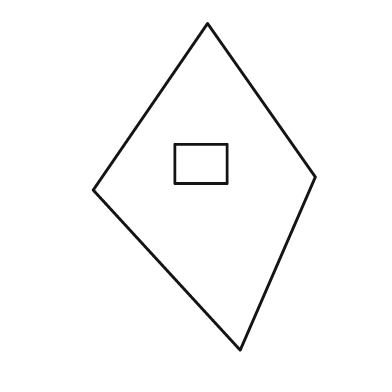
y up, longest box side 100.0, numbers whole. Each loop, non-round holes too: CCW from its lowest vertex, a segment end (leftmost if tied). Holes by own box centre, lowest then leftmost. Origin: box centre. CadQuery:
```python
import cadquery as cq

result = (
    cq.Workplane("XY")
    .moveTo(11.0, -50.0)
    .lineTo(34.0, 3.0)
    .lineTo(1.0, 50.0)
    .lineTo(-34.0, -1.0)
    .close()
    .moveTo(-9.0, 1.0)
    .lineTo(7.0, 1.0)
    .lineTo(7.0, 13.0)
    .lineTo(-9.0, 13.0)
    .close()
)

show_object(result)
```